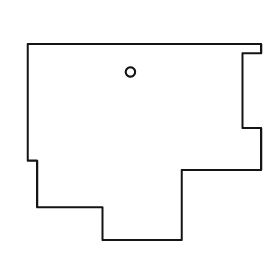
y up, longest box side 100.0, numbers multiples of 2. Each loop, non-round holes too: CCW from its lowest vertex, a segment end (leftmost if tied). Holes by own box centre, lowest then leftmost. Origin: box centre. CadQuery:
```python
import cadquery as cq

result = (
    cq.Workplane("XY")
    .moveTo(-18.0, -42.0)
    .lineTo(16.0, -42.0)
    .lineTo(16.0, -12.0)
    .lineTo(50.0, -12.0)
    .lineTo(50.0, 6.0)
    .lineTo(42.0, 6.0)
    .lineTo(42.0, 38.0)
    .lineTo(50.0, 38.0)
    .lineTo(50.0, 42.0)
    .lineTo(-50.0, 42.0)
    .lineTo(-50.0, -8.0)
    .lineTo(-46.0, -8.0)
    .lineTo(-46.0, -28.0)
    .lineTo(-18.0, -28.0)
    .close()
    .moveTo(-6.0, 30.0)
    .circle(2.0)
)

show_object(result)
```